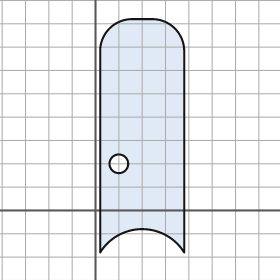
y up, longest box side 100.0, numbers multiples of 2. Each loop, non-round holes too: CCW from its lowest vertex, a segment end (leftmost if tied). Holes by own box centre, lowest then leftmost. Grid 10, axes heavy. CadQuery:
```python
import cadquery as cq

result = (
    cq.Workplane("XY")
    .moveTo(2.0, -18.0)
    .threePointArc((20.0, -8.0), (38.0, -18.0))
    .lineTo(38.0, 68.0)
    .threePointArc((34.0, 78.0), (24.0, 82.0))
    .lineTo(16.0, 82.0)
    .threePointArc((6.0, 78.0), (2.0, 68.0))
    .close()
    .moveTo(10.0, 20.0)
    .circle(4.0)
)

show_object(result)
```